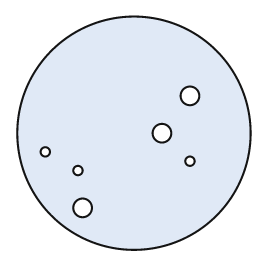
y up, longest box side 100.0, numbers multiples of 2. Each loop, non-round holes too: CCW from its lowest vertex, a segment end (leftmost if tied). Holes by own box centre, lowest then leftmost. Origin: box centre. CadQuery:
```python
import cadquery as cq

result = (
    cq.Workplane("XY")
    .moveTo(0.0, 0.0)
    .circle(50.0)
    .moveTo(-22.0, -32.0)
    .circle(4.0)
    .moveTo(-24.0, -16.0)
    .circle(2.0)
    .moveTo(24.0, -12.0)
    .circle(2.0)
    .moveTo(-38.0, -8.0)
    .circle(2.0)
    .moveTo(12.0, 0.0)
    .circle(4.0)
    .moveTo(24.0, 16.0)
    .circle(4.0)
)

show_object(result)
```